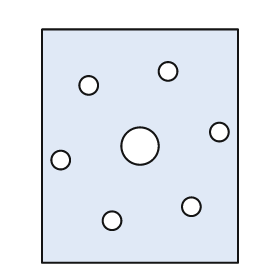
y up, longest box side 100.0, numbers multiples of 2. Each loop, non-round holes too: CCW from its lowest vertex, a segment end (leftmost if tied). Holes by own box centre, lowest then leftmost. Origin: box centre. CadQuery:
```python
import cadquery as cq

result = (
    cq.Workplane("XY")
    .moveTo(-42.0, -50.0)
    .lineTo(42.0, -50.0)
    .lineTo(42.0, 50.0)
    .lineTo(-42.0, 50.0)
    .close()
    .moveTo(-12.0, -32.0)
    .circle(4.0)
    .moveTo(22.0, -26.0)
    .circle(4.0)
    .moveTo(-34.0, -6.0)
    .circle(4.0)
    .moveTo(0.0, 0.0)
    .circle(8.0)
    .moveTo(34.0, 6.0)
    .circle(4.0)
    .moveTo(-22.0, 26.0)
    .circle(4.0)
    .moveTo(12.0, 32.0)
    .circle(4.0)
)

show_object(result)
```